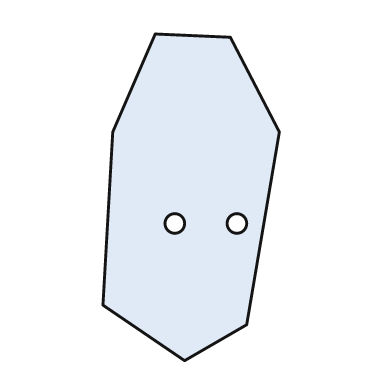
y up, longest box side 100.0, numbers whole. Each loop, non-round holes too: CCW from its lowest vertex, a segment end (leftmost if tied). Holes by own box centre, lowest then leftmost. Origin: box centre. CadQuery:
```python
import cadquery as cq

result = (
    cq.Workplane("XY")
    .moveTo(-2.0, -50.0)
    .lineTo(17.0, -39.0)
    .lineTo(27.0, 20.0)
    .lineTo(12.0, 49.0)
    .lineTo(-11.0, 50.0)
    .lineTo(-24.0, 20.0)
    .lineTo(-27.0, -33.0)
    .close()
    .moveTo(-5.0, -8.0)
    .circle(3.0)
    .moveTo(14.0, -8.0)
    .circle(3.0)
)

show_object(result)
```